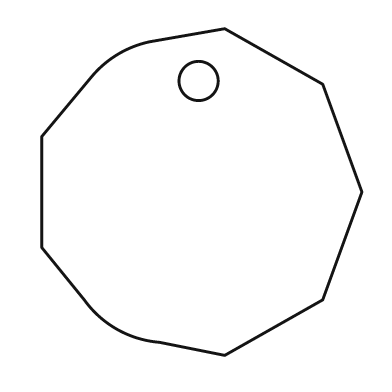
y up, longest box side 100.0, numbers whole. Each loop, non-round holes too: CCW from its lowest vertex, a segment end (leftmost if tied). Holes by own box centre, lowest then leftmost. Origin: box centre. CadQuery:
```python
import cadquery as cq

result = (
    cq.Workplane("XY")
    .moveTo(7.0, -50.0)
    .lineTo(37.0, -33.0)
    .lineTo(49.0, 0.0)
    .lineTo(37.0, 33.0)
    .lineTo(7.0, 50.0)
    .lineTo(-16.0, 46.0)
    .threePointArc((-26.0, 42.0), (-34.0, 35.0))
    .lineTo(-49.0, 17.0)
    .lineTo(-49.0, -17.0)
    .lineTo(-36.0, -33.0)
    .threePointArc((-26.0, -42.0), (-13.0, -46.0))
    .close()
    .moveTo(-1.0, 34.0)
    .circle(6.0)
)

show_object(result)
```